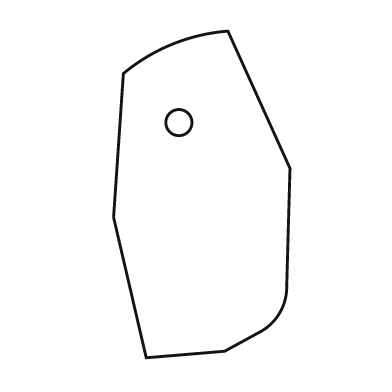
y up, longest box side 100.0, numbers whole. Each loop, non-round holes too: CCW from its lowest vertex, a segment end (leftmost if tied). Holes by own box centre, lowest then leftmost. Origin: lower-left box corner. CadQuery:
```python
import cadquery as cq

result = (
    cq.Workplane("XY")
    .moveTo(10.0, 0.0)
    .lineTo(34.0, 2.0)
    .lineTo(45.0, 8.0)
    .threePointArc((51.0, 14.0), (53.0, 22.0))
    .lineTo(54.0, 58.0)
    .lineTo(35.0, 100.0)
    .threePointArc((18.0, 96.0), (3.0, 87.0))
    .lineTo(0.0, 43.0)
    .close()
    .moveTo(20.0, 72.0)
    .circle(4.0)
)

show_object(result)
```